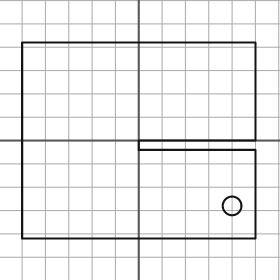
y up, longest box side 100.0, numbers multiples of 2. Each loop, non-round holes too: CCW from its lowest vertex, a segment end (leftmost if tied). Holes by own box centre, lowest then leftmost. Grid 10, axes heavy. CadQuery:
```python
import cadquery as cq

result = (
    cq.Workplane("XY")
    .moveTo(-50.0, -42.0)
    .lineTo(50.0, -42.0)
    .lineTo(50.0, -4.0)
    .lineTo(0.0, -4.0)
    .lineTo(0.0, 0.0)
    .lineTo(50.0, 0.0)
    .lineTo(50.0, 42.0)
    .lineTo(-50.0, 42.0)
    .close()
    .moveTo(40.0, -28.0)
    .circle(4.0)
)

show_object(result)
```